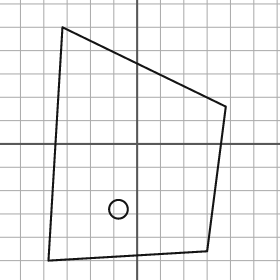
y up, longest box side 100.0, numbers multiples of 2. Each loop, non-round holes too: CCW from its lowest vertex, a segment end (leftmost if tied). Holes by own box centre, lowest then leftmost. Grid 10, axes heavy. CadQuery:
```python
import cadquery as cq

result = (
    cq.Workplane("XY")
    .moveTo(-38.0, -50.0)
    .lineTo(30.0, -46.0)
    .lineTo(38.0, 16.0)
    .lineTo(-32.0, 50.0)
    .close()
    .moveTo(-8.0, -28.0)
    .circle(4.0)
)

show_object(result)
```